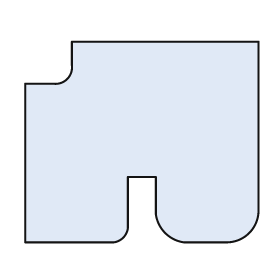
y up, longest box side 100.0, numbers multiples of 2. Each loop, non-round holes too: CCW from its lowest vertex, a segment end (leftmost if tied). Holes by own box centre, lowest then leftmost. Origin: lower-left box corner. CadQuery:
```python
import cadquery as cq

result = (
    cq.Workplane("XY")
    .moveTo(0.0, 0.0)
    .lineTo(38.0, 0.0)
    .threePointArc((42.0, 2.0), (44.0, 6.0))
    .lineTo(44.0, 28.0)
    .lineTo(56.0, 28.0)
    .lineTo(56.0, 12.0)
    .threePointArc((60.0, 4.0), (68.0, 0.0))
    .lineTo(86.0, 0.0)
    .threePointArc((96.0, 4.0), (100.0, 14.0))
    .lineTo(100.0, 86.0)
    .lineTo(20.0, 86.0)
    .lineTo(20.0, 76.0)
    .threePointArc((18.0, 70.0), (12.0, 68.0))
    .lineTo(0.0, 68.0)
    .close()
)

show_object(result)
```